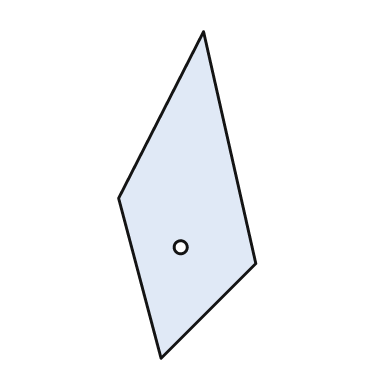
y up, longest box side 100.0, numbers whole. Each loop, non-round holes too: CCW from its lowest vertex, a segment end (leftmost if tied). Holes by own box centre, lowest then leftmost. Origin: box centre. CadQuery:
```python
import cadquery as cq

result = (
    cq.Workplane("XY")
    .moveTo(-8.0, -50.0)
    .lineTo(21.0, -21.0)
    .lineTo(5.0, 50.0)
    .lineTo(-21.0, -1.0)
    .close()
    .moveTo(-2.0, -16.0)
    .circle(2.0)
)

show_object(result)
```